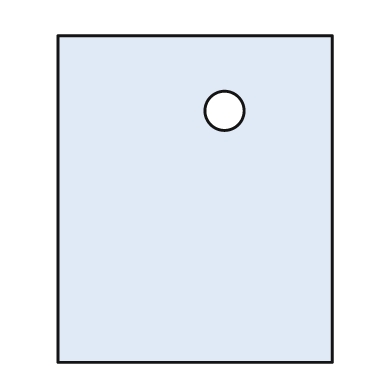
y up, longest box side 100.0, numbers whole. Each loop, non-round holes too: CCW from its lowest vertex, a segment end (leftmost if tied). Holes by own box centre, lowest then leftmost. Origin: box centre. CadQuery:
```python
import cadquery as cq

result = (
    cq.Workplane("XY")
    .moveTo(-42.0, -50.0)
    .lineTo(42.0, -50.0)
    .lineTo(42.0, 50.0)
    .lineTo(-42.0, 50.0)
    .close()
    .moveTo(9.0, 27.0)
    .circle(6.0)
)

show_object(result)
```